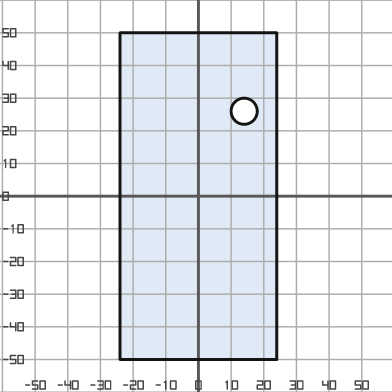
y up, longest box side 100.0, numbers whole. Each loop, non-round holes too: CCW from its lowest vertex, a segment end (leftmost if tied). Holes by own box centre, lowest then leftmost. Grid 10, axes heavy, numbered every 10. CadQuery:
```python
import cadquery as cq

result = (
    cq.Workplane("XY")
    .moveTo(-24.0, -50.0)
    .lineTo(24.0, -50.0)
    .lineTo(24.0, 50.0)
    .lineTo(-24.0, 50.0)
    .close()
    .moveTo(14.0, 26.0)
    .circle(4.0)
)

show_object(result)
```